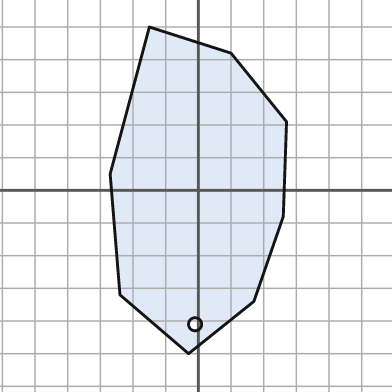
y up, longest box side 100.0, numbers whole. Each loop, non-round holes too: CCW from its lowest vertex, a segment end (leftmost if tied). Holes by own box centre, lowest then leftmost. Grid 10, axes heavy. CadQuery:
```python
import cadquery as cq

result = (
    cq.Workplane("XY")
    .moveTo(-3.0, -50.0)
    .lineTo(17.0, -34.0)
    .lineTo(26.0, -8.0)
    .lineTo(27.0, 21.0)
    .lineTo(10.0, 42.0)
    .lineTo(-15.0, 50.0)
    .lineTo(-27.0, 5.0)
    .lineTo(-24.0, -32.0)
    .close()
    .moveTo(-1.0, -41.0)
    .circle(2.0)
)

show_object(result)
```